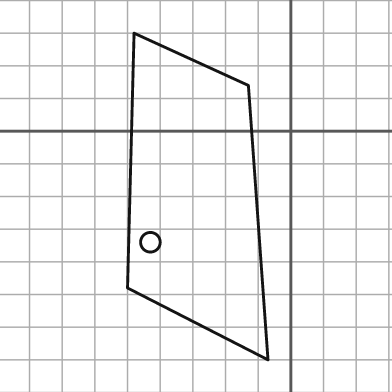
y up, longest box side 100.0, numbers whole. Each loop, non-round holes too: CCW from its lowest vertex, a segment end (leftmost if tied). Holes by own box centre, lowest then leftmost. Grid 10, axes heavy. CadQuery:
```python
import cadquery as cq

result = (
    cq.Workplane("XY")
    .moveTo(-7.0, -70.0)
    .lineTo(-13.0, 14.0)
    .lineTo(-48.0, 30.0)
    .lineTo(-50.0, -48.0)
    .close()
    .moveTo(-43.0, -34.0)
    .circle(3.0)
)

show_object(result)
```